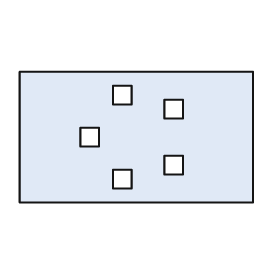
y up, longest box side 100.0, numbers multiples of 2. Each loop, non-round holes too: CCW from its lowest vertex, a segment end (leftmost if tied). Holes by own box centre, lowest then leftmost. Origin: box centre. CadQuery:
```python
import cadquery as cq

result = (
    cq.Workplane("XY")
    .moveTo(-50.0, -28.0)
    .lineTo(50.0, -28.0)
    .lineTo(50.0, 28.0)
    .lineTo(-50.0, 28.0)
    .close()
    .moveTo(-10.0, -22.0)
    .lineTo(-2.0, -22.0)
    .lineTo(-2.0, -14.0)
    .lineTo(-10.0, -14.0)
    .close()
    .moveTo(12.0, -16.0)
    .lineTo(20.0, -16.0)
    .lineTo(20.0, -8.0)
    .lineTo(12.0, -8.0)
    .close()
    .moveTo(-24.0, -4.0)
    .lineTo(-16.0, -4.0)
    .lineTo(-16.0, 4.0)
    .lineTo(-24.0, 4.0)
    .close()
    .moveTo(12.0, 8.0)
    .lineTo(20.0, 8.0)
    .lineTo(20.0, 16.0)
    .lineTo(12.0, 16.0)
    .close()
    .moveTo(-10.0, 14.0)
    .lineTo(-2.0, 14.0)
    .lineTo(-2.0, 22.0)
    .lineTo(-10.0, 22.0)
    .close()
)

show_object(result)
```